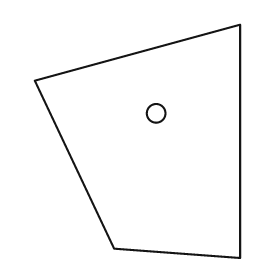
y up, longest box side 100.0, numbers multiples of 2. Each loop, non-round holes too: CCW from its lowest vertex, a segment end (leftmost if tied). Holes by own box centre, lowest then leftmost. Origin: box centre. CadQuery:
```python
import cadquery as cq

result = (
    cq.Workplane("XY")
    .moveTo(44.0, -50.0)
    .lineTo(44.0, 50.0)
    .lineTo(-44.0, 26.0)
    .lineTo(-10.0, -46.0)
    .close()
    .moveTo(8.0, 12.0)
    .circle(4.0)
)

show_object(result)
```